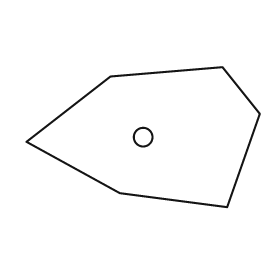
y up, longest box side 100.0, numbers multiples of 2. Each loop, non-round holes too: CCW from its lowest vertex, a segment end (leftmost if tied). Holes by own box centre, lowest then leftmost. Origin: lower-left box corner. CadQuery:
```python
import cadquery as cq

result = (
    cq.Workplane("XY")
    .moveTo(86.0, 0.0)
    .lineTo(100.0, 40.0)
    .lineTo(84.0, 60.0)
    .lineTo(36.0, 56.0)
    .lineTo(0.0, 28.0)
    .lineTo(40.0, 6.0)
    .close()
    .moveTo(50.0, 30.0)
    .circle(4.0)
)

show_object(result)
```